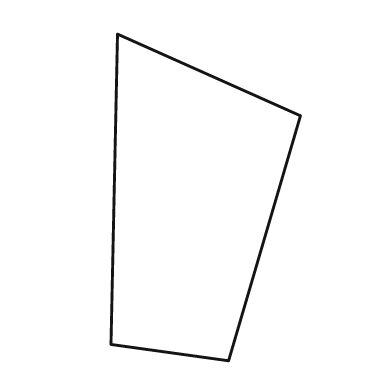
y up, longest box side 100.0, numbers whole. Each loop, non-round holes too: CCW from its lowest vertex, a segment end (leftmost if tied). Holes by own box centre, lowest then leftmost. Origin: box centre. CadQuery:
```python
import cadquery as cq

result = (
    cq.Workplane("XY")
    .moveTo(7.0, -50.0)
    .lineTo(29.0, 25.0)
    .lineTo(-27.0, 50.0)
    .lineTo(-29.0, -45.0)
    .close()
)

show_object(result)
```